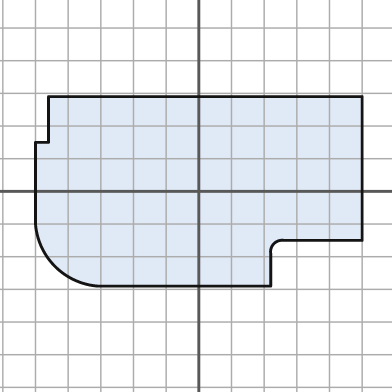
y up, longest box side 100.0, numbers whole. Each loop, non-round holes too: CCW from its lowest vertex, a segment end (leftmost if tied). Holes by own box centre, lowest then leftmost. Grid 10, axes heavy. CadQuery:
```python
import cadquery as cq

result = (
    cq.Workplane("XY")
    .moveTo(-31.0, -29.0)
    .lineTo(22.0, -29.0)
    .lineTo(22.0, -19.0)
    .threePointArc((23.0, -16.0), (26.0, -15.0))
    .lineTo(50.0, -15.0)
    .lineTo(50.0, 29.0)
    .lineTo(-46.0, 29.0)
    .lineTo(-46.0, 15.0)
    .lineTo(-50.0, 15.0)
    .lineTo(-50.0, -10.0)
    .threePointArc((-44.0, -23.0), (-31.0, -29.0))
    .close()
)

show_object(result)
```